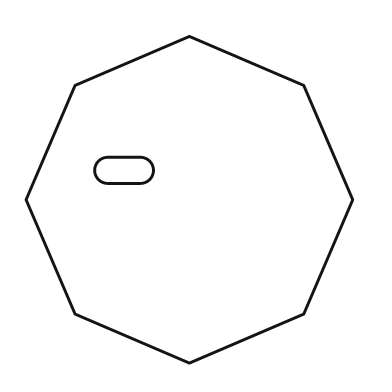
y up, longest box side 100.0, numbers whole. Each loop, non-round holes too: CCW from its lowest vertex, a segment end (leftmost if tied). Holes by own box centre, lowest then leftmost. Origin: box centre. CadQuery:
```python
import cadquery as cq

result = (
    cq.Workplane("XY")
    .moveTo(0.0, -50.0)
    .lineTo(35.0, -35.0)
    .lineTo(50.0, 0.0)
    .lineTo(35.0, 35.0)
    .lineTo(0.0, 50.0)
    .lineTo(-35.0, 35.0)
    .lineTo(-50.0, 0.0)
    .lineTo(-35.0, -35.0)
    .close()
    .moveTo(-25.0, 5.0)
    .lineTo(-15.0, 5.0)
    .threePointArc((-11.0, 9.0), (-15.0, 13.0))
    .lineTo(-25.0, 13.0)
    .threePointArc((-29.0, 9.0), (-25.0, 5.0))
    .close()
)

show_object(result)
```